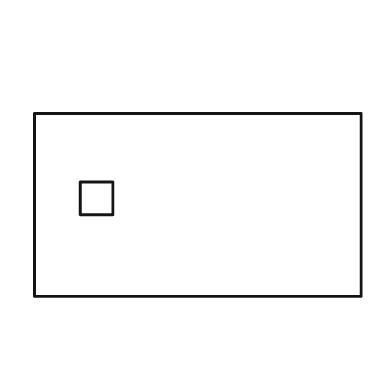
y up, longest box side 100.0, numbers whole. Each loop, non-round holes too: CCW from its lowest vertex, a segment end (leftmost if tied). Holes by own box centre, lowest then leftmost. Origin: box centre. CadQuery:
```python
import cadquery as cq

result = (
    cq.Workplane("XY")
    .moveTo(-50.0, -28.0)
    .lineTo(50.0, -28.0)
    .lineTo(50.0, 28.0)
    .lineTo(-50.0, 28.0)
    .close()
    .moveTo(-36.0, -3.0)
    .lineTo(-26.0, -3.0)
    .lineTo(-26.0, 7.0)
    .lineTo(-36.0, 7.0)
    .close()
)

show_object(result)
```